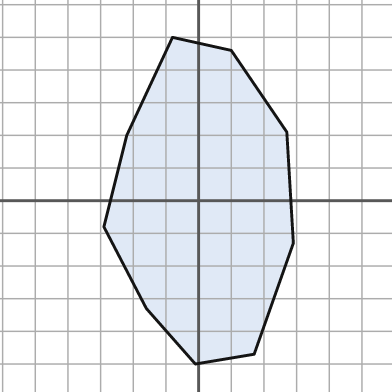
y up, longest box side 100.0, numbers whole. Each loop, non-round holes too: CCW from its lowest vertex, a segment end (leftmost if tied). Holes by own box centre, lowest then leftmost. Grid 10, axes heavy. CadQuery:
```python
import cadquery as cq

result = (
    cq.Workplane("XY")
    .moveTo(-1.0, -50.0)
    .lineTo(17.0, -47.0)
    .lineTo(29.0, -13.0)
    .lineTo(27.0, 21.0)
    .lineTo(10.0, 46.0)
    .lineTo(-8.0, 50.0)
    .lineTo(-22.0, 20.0)
    .lineTo(-29.0, -8.0)
    .lineTo(-16.0, -33.0)
    .close()
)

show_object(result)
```